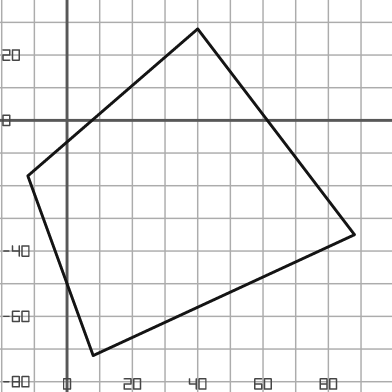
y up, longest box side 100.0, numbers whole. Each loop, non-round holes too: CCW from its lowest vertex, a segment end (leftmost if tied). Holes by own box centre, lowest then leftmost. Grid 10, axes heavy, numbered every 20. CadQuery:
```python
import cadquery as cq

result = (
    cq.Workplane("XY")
    .moveTo(8.0, -72.0)
    .lineTo(88.0, -35.0)
    .lineTo(40.0, 28.0)
    .lineTo(-12.0, -17.0)
    .close()
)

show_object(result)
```